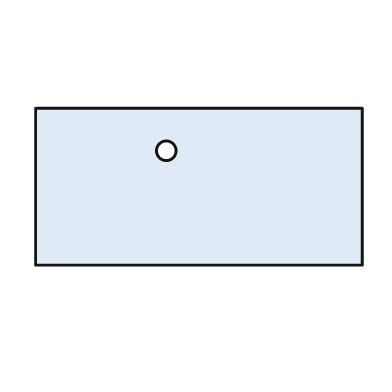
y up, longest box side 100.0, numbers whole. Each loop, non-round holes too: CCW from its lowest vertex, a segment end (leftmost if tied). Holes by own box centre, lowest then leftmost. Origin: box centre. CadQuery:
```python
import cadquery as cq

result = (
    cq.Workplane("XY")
    .moveTo(-50.0, -24.0)
    .lineTo(50.0, -24.0)
    .lineTo(50.0, 24.0)
    .lineTo(-50.0, 24.0)
    .close()
    .moveTo(-10.0, 11.0)
    .circle(3.0)
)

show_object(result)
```